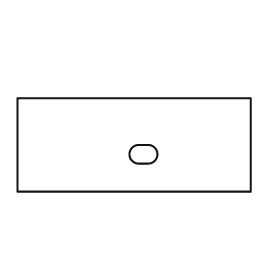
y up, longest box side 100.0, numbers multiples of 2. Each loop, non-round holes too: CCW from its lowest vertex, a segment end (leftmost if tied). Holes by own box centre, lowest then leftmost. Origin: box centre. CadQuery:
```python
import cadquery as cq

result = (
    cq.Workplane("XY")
    .moveTo(-50.0, -20.0)
    .lineTo(50.0, -20.0)
    .lineTo(50.0, 20.0)
    .lineTo(-50.0, 20.0)
    .close()
    .moveTo(2.0, -8.0)
    .lineTo(6.0, -8.0)
    .threePointArc((10.0, -4.0), (6.0, 0.0))
    .lineTo(2.0, 0.0)
    .threePointArc((-2.0, -4.0), (2.0, -8.0))
    .close()
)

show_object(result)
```